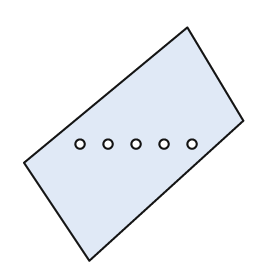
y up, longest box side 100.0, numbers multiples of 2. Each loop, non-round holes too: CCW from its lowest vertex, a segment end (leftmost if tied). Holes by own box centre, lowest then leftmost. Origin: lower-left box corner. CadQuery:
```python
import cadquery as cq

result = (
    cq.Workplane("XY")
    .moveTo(28.0, 0.0)
    .lineTo(94.0, 60.0)
    .lineTo(70.0, 100.0)
    .lineTo(0.0, 42.0)
    .close()
    .moveTo(24.0, 50.0)
    .circle(2.0)
    .moveTo(36.0, 50.0)
    .circle(2.0)
    .moveTo(48.0, 50.0)
    .circle(2.0)
    .moveTo(60.0, 50.0)
    .circle(2.0)
    .moveTo(72.0, 50.0)
    .circle(2.0)
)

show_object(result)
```